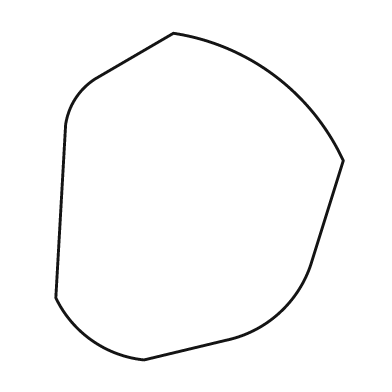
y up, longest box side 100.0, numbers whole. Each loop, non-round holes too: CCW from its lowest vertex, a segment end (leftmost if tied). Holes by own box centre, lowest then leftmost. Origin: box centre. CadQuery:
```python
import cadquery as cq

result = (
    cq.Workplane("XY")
    .moveTo(-17.0, -50.0)
    .lineTo(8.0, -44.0)
    .threePointArc((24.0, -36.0), (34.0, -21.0))
    .lineTo(44.0, 11.0)
    .threePointArc((23.0, 37.0), (-8.0, 50.0))
    .lineTo(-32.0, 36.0)
    .threePointArc((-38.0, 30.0), (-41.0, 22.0))
    .lineTo(-44.0, -31.0)
    .threePointArc((-33.0, -44.0), (-17.0, -50.0))
    .close()
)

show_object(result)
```